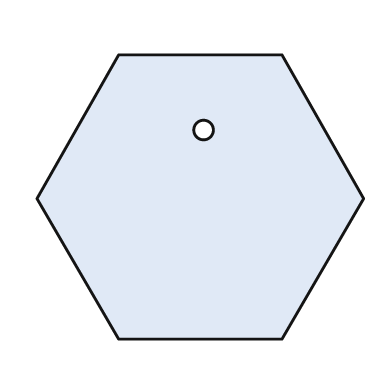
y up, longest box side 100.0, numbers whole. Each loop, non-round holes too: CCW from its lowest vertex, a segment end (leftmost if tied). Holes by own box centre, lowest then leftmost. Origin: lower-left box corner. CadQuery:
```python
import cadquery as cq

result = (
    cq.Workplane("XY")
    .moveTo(25.0, 0.0)
    .lineTo(75.0, 0.0)
    .lineTo(100.0, 43.0)
    .lineTo(75.0, 87.0)
    .lineTo(25.0, 87.0)
    .lineTo(0.0, 43.0)
    .close()
    .moveTo(51.0, 64.0)
    .circle(3.0)
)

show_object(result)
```